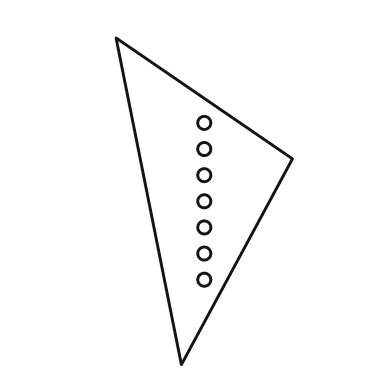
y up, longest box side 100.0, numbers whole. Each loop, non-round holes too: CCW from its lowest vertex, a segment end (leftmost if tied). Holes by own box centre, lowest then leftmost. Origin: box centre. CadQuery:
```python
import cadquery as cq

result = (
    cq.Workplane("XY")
    .moveTo(-7.0, -50.0)
    .lineTo(27.0, 13.0)
    .lineTo(-27.0, 50.0)
    .close()
    .moveTo(0.0, -24.0)
    .circle(2.0)
    .moveTo(0.0, -16.0)
    .circle(2.0)
    .moveTo(0.0, -8.0)
    .circle(2.0)
    .moveTo(0.0, 0.0)
    .circle(2.0)
    .moveTo(0.0, 8.0)
    .circle(2.0)
    .moveTo(0.0, 16.0)
    .circle(2.0)
    .moveTo(0.0, 24.0)
    .circle(2.0)
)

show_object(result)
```